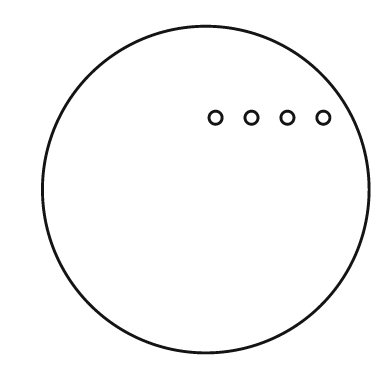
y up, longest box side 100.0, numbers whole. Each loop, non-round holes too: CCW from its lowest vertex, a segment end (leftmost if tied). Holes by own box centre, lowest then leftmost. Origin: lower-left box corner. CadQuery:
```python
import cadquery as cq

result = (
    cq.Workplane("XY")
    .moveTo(50.0, 50.0)
    .circle(50.0)
    .moveTo(53.0, 72.0)
    .circle(2.0)
    .moveTo(64.0, 72.0)
    .circle(2.0)
    .moveTo(75.0, 72.0)
    .circle(2.0)
    .moveTo(86.0, 72.0)
    .circle(2.0)
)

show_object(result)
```